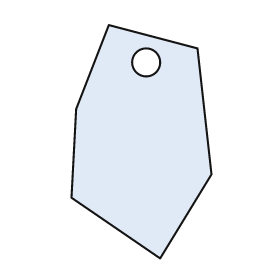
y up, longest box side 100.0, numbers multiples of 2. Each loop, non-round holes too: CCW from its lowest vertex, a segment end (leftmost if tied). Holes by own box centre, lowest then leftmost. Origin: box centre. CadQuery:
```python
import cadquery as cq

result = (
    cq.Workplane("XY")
    .moveTo(8.0, -50.0)
    .lineTo(30.0, -14.0)
    .lineTo(24.0, 40.0)
    .lineTo(-14.0, 50.0)
    .lineTo(-28.0, 14.0)
    .lineTo(-30.0, -24.0)
    .close()
    .moveTo(2.0, 34.0)
    .circle(6.0)
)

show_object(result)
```